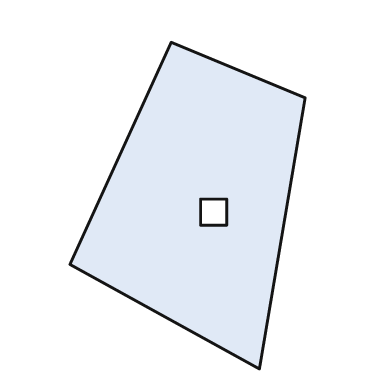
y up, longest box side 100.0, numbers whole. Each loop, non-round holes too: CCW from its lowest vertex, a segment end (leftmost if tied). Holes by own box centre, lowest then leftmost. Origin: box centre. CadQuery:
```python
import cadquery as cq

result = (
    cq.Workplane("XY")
    .moveTo(22.0, -50.0)
    .lineTo(36.0, 33.0)
    .lineTo(-5.0, 50.0)
    .lineTo(-36.0, -18.0)
    .close()
    .moveTo(4.0, -6.0)
    .lineTo(12.0, -6.0)
    .lineTo(12.0, 2.0)
    .lineTo(4.0, 2.0)
    .close()
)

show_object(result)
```